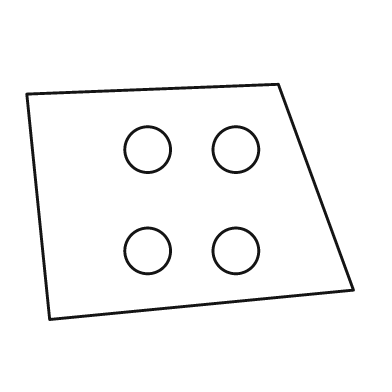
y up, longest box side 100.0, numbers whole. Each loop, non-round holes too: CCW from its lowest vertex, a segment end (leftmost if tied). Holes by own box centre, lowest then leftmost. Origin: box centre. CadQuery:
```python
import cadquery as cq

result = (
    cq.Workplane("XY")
    .moveTo(-43.0, -36.0)
    .lineTo(50.0, -27.0)
    .lineTo(27.0, 36.0)
    .lineTo(-50.0, 33.0)
    .close()
    .moveTo(-13.0, -15.0)
    .circle(7.0)
    .moveTo(14.0, -15.0)
    .circle(7.0)
    .moveTo(-13.0, 16.0)
    .circle(7.0)
    .moveTo(14.0, 16.0)
    .circle(7.0)
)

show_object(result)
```